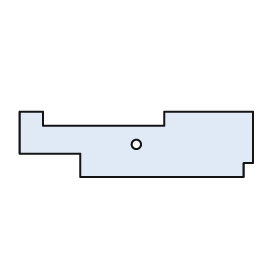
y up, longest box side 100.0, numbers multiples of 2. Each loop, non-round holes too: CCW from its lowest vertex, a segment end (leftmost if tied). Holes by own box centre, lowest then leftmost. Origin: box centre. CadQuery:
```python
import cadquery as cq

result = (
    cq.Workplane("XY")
    .moveTo(-24.0, -14.0)
    .lineTo(46.0, -14.0)
    .lineTo(46.0, -8.0)
    .lineTo(50.0, -8.0)
    .lineTo(50.0, 14.0)
    .lineTo(12.0, 14.0)
    .lineTo(12.0, 8.0)
    .lineTo(-40.0, 8.0)
    .lineTo(-40.0, 14.0)
    .lineTo(-50.0, 14.0)
    .lineTo(-50.0, -4.0)
    .lineTo(-24.0, -4.0)
    .close()
    .moveTo(0.0, 0.0)
    .circle(2.0)
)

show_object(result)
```